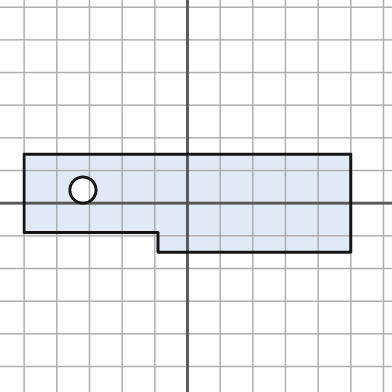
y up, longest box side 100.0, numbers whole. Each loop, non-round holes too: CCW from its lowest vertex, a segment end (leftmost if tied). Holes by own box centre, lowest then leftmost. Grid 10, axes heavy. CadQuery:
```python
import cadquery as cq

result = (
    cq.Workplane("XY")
    .moveTo(-9.0, -15.0)
    .lineTo(50.0, -15.0)
    .lineTo(50.0, 15.0)
    .lineTo(-50.0, 15.0)
    .lineTo(-50.0, -9.0)
    .lineTo(-9.0, -9.0)
    .close()
    .moveTo(-32.0, 4.0)
    .circle(4.0)
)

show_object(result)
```